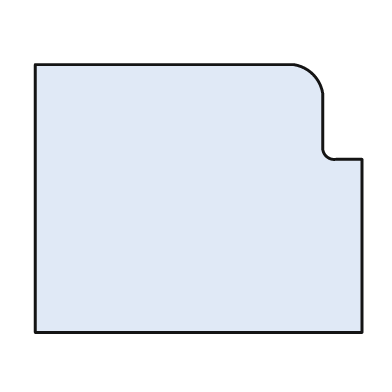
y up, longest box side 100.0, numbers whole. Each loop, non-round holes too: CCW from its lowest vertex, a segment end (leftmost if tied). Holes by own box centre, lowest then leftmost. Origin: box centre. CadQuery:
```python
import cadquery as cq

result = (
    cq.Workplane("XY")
    .moveTo(-50.0, -41.0)
    .lineTo(50.0, -41.0)
    .lineTo(50.0, 12.0)
    .lineTo(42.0, 12.0)
    .threePointArc((39.0, 13.0), (38.0, 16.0))
    .lineTo(38.0, 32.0)
    .threePointArc((35.0, 38.0), (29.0, 41.0))
    .lineTo(-50.0, 41.0)
    .close()
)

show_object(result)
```